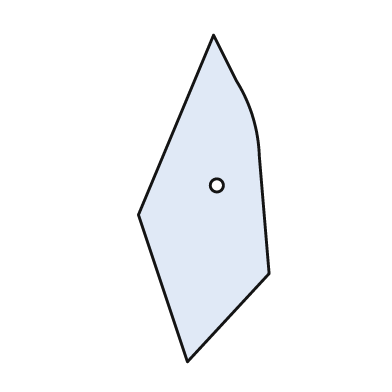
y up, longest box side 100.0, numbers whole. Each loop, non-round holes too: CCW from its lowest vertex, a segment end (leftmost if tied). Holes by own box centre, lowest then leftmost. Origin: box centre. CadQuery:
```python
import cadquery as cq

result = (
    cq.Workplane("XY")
    .moveTo(-5.0, -50.0)
    .lineTo(20.0, -23.0)
    .lineTo(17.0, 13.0)
    .threePointArc((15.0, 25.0), (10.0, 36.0))
    .lineTo(3.0, 50.0)
    .lineTo(-20.0, -5.0)
    .close()
    .moveTo(4.0, 4.0)
    .circle(2.0)
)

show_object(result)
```